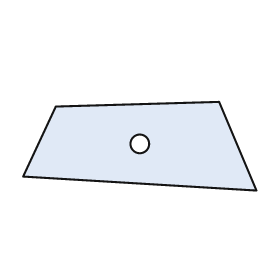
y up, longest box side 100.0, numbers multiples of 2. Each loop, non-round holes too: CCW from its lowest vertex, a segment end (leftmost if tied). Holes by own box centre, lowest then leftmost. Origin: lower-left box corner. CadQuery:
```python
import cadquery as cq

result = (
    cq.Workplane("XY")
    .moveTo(100.0, 0.0)
    .lineTo(84.0, 38.0)
    .lineTo(14.0, 36.0)
    .lineTo(0.0, 6.0)
    .close()
    .moveTo(50.0, 20.0)
    .circle(4.0)
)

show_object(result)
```